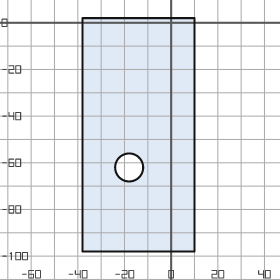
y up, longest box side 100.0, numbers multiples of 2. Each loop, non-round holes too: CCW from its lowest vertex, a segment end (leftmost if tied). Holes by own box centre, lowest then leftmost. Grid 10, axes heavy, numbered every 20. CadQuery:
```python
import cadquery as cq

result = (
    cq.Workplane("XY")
    .moveTo(-38.0, -98.0)
    .lineTo(10.0, -98.0)
    .lineTo(10.0, 2.0)
    .lineTo(-38.0, 2.0)
    .close()
    .moveTo(-18.0, -62.0)
    .circle(6.0)
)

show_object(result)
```